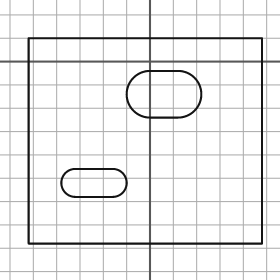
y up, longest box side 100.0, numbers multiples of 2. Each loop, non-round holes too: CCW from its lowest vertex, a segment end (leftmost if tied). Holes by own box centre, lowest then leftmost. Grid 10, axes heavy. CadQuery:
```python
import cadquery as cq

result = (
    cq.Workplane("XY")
    .moveTo(-52.0, -78.0)
    .lineTo(48.0, -78.0)
    .lineTo(48.0, 10.0)
    .lineTo(-52.0, 10.0)
    .close()
    .moveTo(-32.0, -58.0)
    .lineTo(-16.0, -58.0)
    .threePointArc((-10.0, -52.0), (-16.0, -46.0))
    .lineTo(-32.0, -46.0)
    .threePointArc((-38.0, -52.0), (-32.0, -58.0))
    .close()
    .moveTo(0.0, -24.0)
    .lineTo(12.0, -24.0)
    .threePointArc((22.0, -14.0), (12.0, -4.0))
    .lineTo(0.0, -4.0)
    .threePointArc((-10.0, -14.0), (0.0, -24.0))
    .close()
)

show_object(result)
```